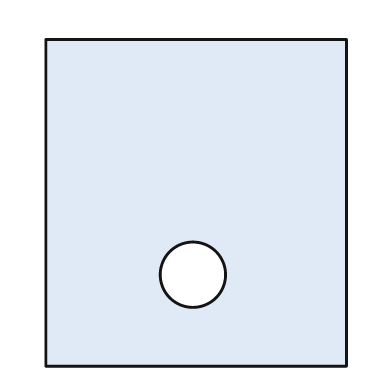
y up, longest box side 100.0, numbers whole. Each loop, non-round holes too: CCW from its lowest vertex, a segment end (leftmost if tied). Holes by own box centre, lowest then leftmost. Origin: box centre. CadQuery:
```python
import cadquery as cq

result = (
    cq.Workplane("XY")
    .moveTo(-46.0, -50.0)
    .lineTo(46.0, -50.0)
    .lineTo(46.0, 50.0)
    .lineTo(-46.0, 50.0)
    .close()
    .moveTo(-1.0, -22.0)
    .circle(10.0)
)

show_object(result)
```